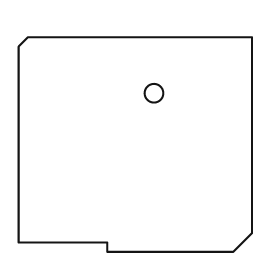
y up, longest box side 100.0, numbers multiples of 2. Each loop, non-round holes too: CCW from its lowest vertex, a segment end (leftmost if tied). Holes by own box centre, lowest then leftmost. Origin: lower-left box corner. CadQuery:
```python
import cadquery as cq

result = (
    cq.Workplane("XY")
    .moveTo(38.0, 0.0)
    .lineTo(92.0, 0.0)
    .lineTo(100.0, 8.0)
    .lineTo(100.0, 92.0)
    .lineTo(4.0, 92.0)
    .lineTo(0.0, 88.0)
    .lineTo(0.0, 4.0)
    .lineTo(38.0, 4.0)
    .close()
    .moveTo(58.0, 68.0)
    .circle(4.0)
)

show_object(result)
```